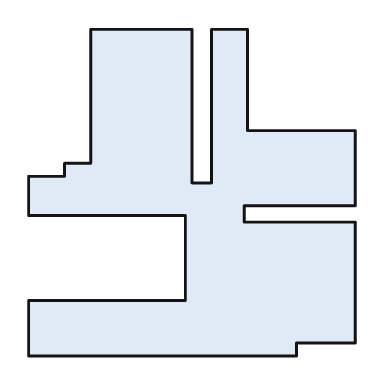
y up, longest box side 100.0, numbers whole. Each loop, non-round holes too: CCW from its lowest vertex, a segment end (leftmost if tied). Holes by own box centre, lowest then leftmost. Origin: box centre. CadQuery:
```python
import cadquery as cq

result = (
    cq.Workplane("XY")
    .moveTo(-50.0, -50.0)
    .lineTo(32.0, -50.0)
    .lineTo(32.0, -46.0)
    .lineTo(50.0, -46.0)
    .lineTo(50.0, -9.0)
    .lineTo(16.0, -9.0)
    .lineTo(16.0, -4.0)
    .lineTo(50.0, -4.0)
    .lineTo(50.0, 19.0)
    .lineTo(17.0, 19.0)
    .lineTo(17.0, 50.0)
    .lineTo(6.0, 50.0)
    .lineTo(6.0, 3.0)
    .lineTo(0.0, 3.0)
    .lineTo(0.0, 50.0)
    .lineTo(-31.0, 50.0)
    .lineTo(-31.0, 9.0)
    .lineTo(-39.0, 9.0)
    .lineTo(-39.0, 5.0)
    .lineTo(-50.0, 5.0)
    .lineTo(-50.0, -7.0)
    .lineTo(-2.0, -7.0)
    .lineTo(-2.0, -33.0)
    .lineTo(-50.0, -33.0)
    .close()
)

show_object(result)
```